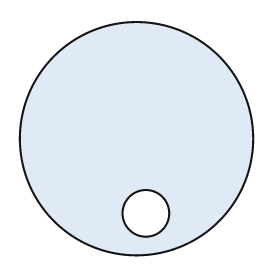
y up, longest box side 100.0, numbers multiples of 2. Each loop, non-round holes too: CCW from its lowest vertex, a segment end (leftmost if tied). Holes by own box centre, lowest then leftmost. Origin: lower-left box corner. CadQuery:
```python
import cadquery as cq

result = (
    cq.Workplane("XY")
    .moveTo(50.0, 50.0)
    .circle(50.0)
    .moveTo(54.0, 18.0)
    .circle(10.0)
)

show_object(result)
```